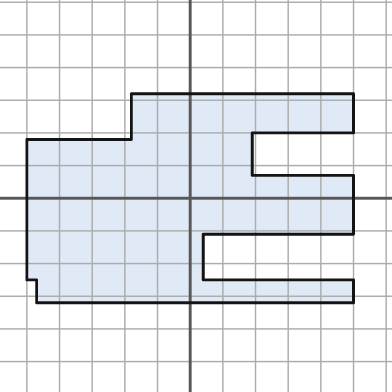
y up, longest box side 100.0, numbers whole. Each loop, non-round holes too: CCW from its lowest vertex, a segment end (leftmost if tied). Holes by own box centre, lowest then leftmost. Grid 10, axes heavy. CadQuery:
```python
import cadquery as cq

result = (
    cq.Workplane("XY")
    .moveTo(-47.0, -32.0)
    .lineTo(50.0, -32.0)
    .lineTo(50.0, -25.0)
    .lineTo(4.0, -25.0)
    .lineTo(4.0, -11.0)
    .lineTo(50.0, -11.0)
    .lineTo(50.0, 7.0)
    .lineTo(19.0, 7.0)
    .lineTo(19.0, 20.0)
    .lineTo(50.0, 20.0)
    .lineTo(50.0, 32.0)
    .lineTo(-18.0, 32.0)
    .lineTo(-18.0, 18.0)
    .lineTo(-50.0, 18.0)
    .lineTo(-50.0, -25.0)
    .lineTo(-47.0, -25.0)
    .close()
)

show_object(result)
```